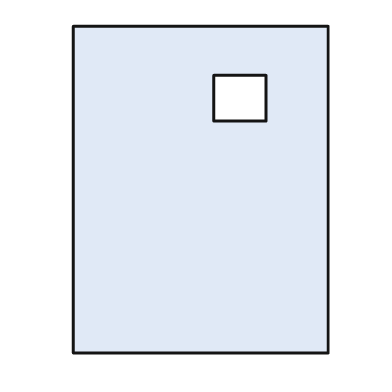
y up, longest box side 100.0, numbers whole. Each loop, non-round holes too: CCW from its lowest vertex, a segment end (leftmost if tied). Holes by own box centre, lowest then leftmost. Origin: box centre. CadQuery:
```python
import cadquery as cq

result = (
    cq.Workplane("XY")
    .moveTo(-39.0, -50.0)
    .lineTo(39.0, -50.0)
    .lineTo(39.0, 50.0)
    .lineTo(-39.0, 50.0)
    .close()
    .moveTo(4.0, 21.0)
    .lineTo(20.0, 21.0)
    .lineTo(20.0, 35.0)
    .lineTo(4.0, 35.0)
    .close()
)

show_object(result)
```